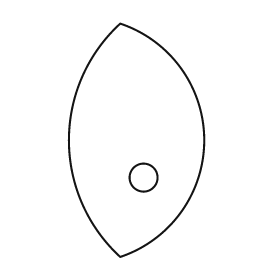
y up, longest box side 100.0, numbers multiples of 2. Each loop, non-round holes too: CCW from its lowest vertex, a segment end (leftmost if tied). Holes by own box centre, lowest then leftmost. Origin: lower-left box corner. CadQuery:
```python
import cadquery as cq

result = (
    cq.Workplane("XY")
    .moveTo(22.0, 0.0)
    .threePointArc((58.0, 50.0), (22.0, 100.0))
    .threePointArc((0.0, 50.0), (22.0, 0.0))
    .close()
    .moveTo(32.0, 34.0)
    .circle(6.0)
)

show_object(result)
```